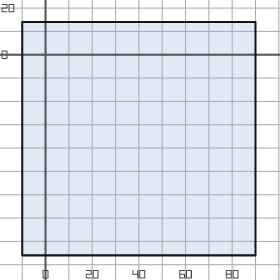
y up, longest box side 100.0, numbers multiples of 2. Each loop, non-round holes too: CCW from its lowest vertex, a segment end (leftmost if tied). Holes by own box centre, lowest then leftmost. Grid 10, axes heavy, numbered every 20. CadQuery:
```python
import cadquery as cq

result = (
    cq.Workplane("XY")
    .moveTo(-10.0, -86.0)
    .lineTo(90.0, -86.0)
    .lineTo(90.0, 14.0)
    .lineTo(-10.0, 14.0)
    .close()
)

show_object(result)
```